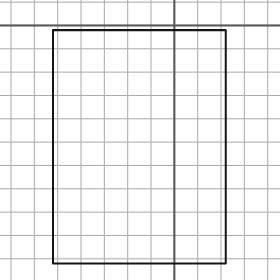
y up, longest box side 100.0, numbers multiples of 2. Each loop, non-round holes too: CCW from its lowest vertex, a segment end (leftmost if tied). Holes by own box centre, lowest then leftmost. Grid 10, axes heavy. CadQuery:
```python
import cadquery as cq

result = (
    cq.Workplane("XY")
    .moveTo(-52.0, -102.0)
    .lineTo(22.0, -102.0)
    .lineTo(22.0, -2.0)
    .lineTo(-52.0, -2.0)
    .close()
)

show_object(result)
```